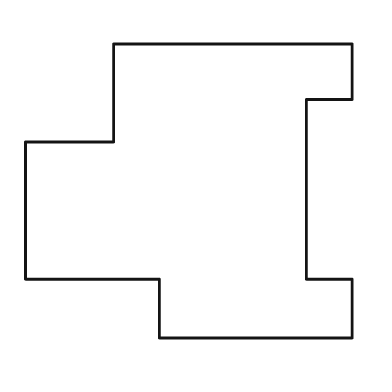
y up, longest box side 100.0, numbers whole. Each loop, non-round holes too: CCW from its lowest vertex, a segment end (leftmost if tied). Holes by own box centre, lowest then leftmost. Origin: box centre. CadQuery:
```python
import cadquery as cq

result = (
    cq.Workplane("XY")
    .moveTo(-9.0, -45.0)
    .lineTo(50.0, -45.0)
    .lineTo(50.0, -27.0)
    .lineTo(36.0, -27.0)
    .lineTo(36.0, 28.0)
    .lineTo(50.0, 28.0)
    .lineTo(50.0, 45.0)
    .lineTo(-23.0, 45.0)
    .lineTo(-23.0, 15.0)
    .lineTo(-50.0, 15.0)
    .lineTo(-50.0, -27.0)
    .lineTo(-9.0, -27.0)
    .close()
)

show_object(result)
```